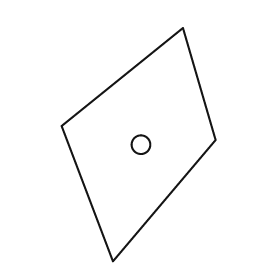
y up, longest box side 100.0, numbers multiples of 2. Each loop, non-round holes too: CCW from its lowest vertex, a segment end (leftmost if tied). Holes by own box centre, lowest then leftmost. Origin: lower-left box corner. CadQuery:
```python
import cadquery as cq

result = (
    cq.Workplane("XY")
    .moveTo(22.0, 0.0)
    .lineTo(66.0, 52.0)
    .lineTo(52.0, 100.0)
    .lineTo(0.0, 58.0)
    .close()
    .moveTo(34.0, 50.0)
    .circle(4.0)
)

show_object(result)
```